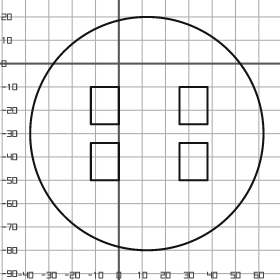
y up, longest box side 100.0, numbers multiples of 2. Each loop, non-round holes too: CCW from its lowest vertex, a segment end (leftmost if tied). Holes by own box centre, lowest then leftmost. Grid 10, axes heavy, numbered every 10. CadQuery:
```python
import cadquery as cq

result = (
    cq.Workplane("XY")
    .moveTo(12.0, -30.0)
    .circle(50.0)
    .moveTo(-12.0, -50.0)
    .lineTo(0.0, -50.0)
    .lineTo(0.0, -34.0)
    .lineTo(-12.0, -34.0)
    .close()
    .moveTo(26.0, -50.0)
    .lineTo(38.0, -50.0)
    .lineTo(38.0, -34.0)
    .lineTo(26.0, -34.0)
    .close()
    .moveTo(-12.0, -26.0)
    .lineTo(0.0, -26.0)
    .lineTo(0.0, -10.0)
    .lineTo(-12.0, -10.0)
    .close()
    .moveTo(26.0, -26.0)
    .lineTo(38.0, -26.0)
    .lineTo(38.0, -10.0)
    .lineTo(26.0, -10.0)
    .close()
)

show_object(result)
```